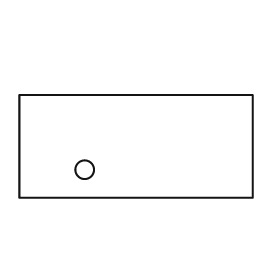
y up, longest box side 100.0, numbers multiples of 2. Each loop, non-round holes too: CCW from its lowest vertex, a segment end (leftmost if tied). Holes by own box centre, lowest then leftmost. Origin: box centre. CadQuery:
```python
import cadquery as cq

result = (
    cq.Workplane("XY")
    .moveTo(-50.0, -22.0)
    .lineTo(50.0, -22.0)
    .lineTo(50.0, 22.0)
    .lineTo(-50.0, 22.0)
    .close()
    .moveTo(-22.0, -10.0)
    .circle(4.0)
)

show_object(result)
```